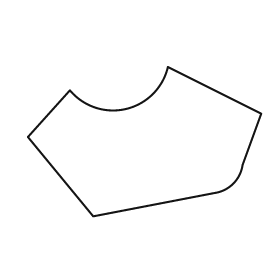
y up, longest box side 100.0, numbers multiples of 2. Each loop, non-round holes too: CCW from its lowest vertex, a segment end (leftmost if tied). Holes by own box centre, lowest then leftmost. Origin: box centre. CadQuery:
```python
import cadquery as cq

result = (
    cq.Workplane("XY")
    .moveTo(-22.0, -32.0)
    .lineTo(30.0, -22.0)
    .threePointArc((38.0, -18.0), (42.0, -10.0))
    .lineTo(50.0, 12.0)
    .lineTo(10.0, 32.0)
    .threePointArc((-8.0, 14.0), (-32.0, 22.0))
    .lineTo(-50.0, 2.0)
    .close()
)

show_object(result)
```